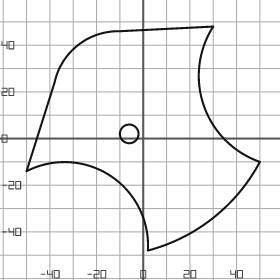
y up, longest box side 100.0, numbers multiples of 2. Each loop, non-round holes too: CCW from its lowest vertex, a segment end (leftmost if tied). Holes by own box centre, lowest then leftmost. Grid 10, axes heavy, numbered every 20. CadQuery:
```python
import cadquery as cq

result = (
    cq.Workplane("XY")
    .moveTo(2.0, -48.0)
    .threePointArc((30.0, -34.0), (50.0, -10.0))
    .threePointArc((26.0, 14.0), (30.0, 48.0))
    .lineTo(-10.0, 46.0)
    .threePointArc((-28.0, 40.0), (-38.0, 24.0))
    .lineTo(-50.0, -14.0)
    .threePointArc((-14.0, -16.0), (2.0, -48.0))
    .close()
    .moveTo(-6.0, 2.0)
    .circle(4.0)
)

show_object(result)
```